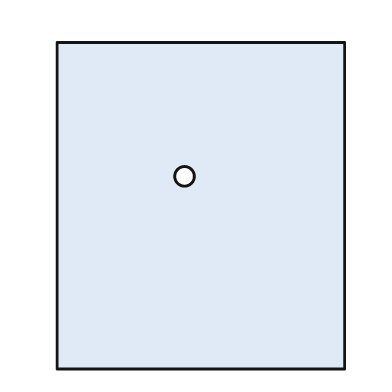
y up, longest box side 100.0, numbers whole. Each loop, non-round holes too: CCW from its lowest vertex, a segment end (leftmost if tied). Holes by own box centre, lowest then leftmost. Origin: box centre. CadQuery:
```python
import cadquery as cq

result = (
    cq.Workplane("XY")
    .moveTo(-44.0, -50.0)
    .lineTo(44.0, -50.0)
    .lineTo(44.0, 50.0)
    .lineTo(-44.0, 50.0)
    .close()
    .moveTo(-5.0, 9.0)
    .circle(3.0)
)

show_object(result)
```